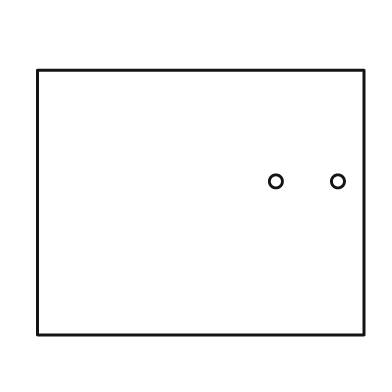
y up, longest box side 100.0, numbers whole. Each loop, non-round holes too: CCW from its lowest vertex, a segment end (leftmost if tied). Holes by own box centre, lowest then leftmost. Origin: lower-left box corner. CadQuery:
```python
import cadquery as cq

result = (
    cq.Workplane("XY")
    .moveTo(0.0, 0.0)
    .lineTo(100.0, 0.0)
    .lineTo(100.0, 81.0)
    .lineTo(0.0, 81.0)
    .close()
    .moveTo(73.0, 47.0)
    .circle(2.0)
    .moveTo(92.0, 47.0)
    .circle(2.0)
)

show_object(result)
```